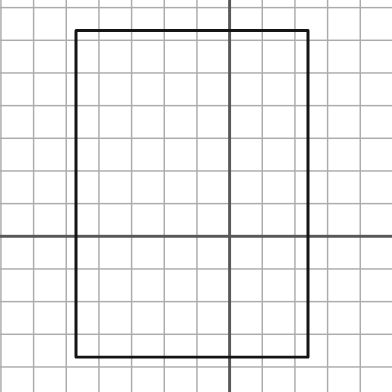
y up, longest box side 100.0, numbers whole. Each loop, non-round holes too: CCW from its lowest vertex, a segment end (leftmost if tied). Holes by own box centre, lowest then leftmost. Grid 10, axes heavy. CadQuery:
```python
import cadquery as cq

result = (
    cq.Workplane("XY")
    .moveTo(-47.0, -37.0)
    .lineTo(24.0, -37.0)
    .lineTo(24.0, 63.0)
    .lineTo(-47.0, 63.0)
    .close()
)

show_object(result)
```